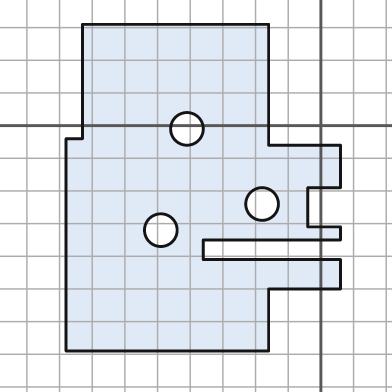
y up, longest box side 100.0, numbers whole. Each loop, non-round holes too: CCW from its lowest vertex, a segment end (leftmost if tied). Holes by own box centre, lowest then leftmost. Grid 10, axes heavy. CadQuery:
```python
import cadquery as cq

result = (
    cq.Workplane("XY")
    .moveTo(-78.0, -69.0)
    .lineTo(-16.0, -69.0)
    .lineTo(-16.0, -50.0)
    .lineTo(6.0, -50.0)
    .lineTo(6.0, -41.0)
    .lineTo(-36.0, -41.0)
    .lineTo(-36.0, -35.0)
    .lineTo(6.0, -35.0)
    .lineTo(6.0, -31.0)
    .lineTo(-4.0, -31.0)
    .lineTo(-4.0, -19.0)
    .lineTo(6.0, -19.0)
    .lineTo(6.0, -6.0)
    .lineTo(-16.0, -6.0)
    .lineTo(-16.0, 31.0)
    .lineTo(-73.0, 31.0)
    .lineTo(-73.0, -4.0)
    .lineTo(-78.0, -4.0)
    .close()
    .moveTo(-49.0, -32.0)
    .circle(5.0)
    .moveTo(-18.0, -24.0)
    .circle(5.0)
    .moveTo(-41.0, -1.0)
    .circle(5.0)
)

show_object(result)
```